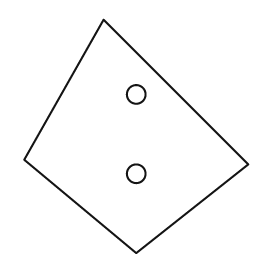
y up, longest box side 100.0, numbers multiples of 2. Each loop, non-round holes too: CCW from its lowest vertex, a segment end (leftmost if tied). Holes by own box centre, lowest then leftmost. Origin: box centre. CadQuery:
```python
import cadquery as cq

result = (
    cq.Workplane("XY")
    .moveTo(0.0, -50.0)
    .lineTo(48.0, -12.0)
    .lineTo(-14.0, 50.0)
    .lineTo(-48.0, -10.0)
    .close()
    .moveTo(0.0, -16.0)
    .circle(4.0)
    .moveTo(0.0, 18.0)
    .circle(4.0)
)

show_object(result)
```